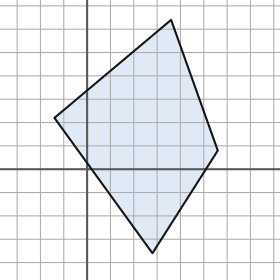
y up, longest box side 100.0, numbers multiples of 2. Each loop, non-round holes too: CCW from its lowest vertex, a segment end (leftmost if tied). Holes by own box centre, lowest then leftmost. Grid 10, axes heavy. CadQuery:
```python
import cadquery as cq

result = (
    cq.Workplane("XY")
    .moveTo(28.0, -36.0)
    .lineTo(56.0, 8.0)
    .lineTo(36.0, 64.0)
    .lineTo(-14.0, 22.0)
    .close()
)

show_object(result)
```